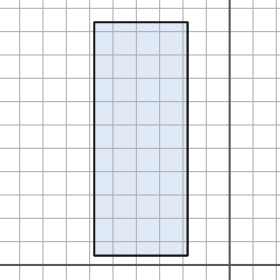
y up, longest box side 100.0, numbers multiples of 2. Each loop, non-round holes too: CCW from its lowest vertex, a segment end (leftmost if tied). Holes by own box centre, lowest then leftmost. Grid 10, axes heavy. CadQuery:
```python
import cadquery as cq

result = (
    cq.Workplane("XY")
    .moveTo(-58.0, 4.0)
    .lineTo(-18.0, 4.0)
    .lineTo(-18.0, 104.0)
    .lineTo(-58.0, 104.0)
    .close()
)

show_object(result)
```